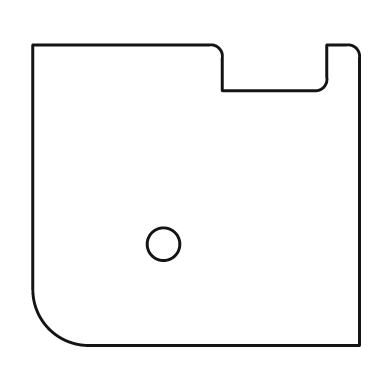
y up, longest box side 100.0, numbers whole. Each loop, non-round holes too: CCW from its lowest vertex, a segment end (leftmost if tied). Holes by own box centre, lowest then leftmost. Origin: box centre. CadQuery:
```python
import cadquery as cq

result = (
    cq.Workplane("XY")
    .moveTo(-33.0, -46.0)
    .lineTo(50.0, -46.0)
    .lineTo(50.0, 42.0)
    .threePointArc((49.0, 45.0), (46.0, 46.0))
    .lineTo(40.0, 46.0)
    .lineTo(40.0, 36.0)
    .threePointArc((39.0, 33.0), (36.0, 32.0))
    .lineTo(8.0, 32.0)
    .lineTo(8.0, 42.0)
    .threePointArc((7.0, 45.0), (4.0, 46.0))
    .lineTo(-50.0, 46.0)
    .lineTo(-50.0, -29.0)
    .threePointArc((-45.0, -41.0), (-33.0, -46.0))
    .close()
    .moveTo(-10.0, -15.0)
    .circle(5.0)
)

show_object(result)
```